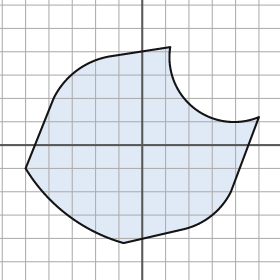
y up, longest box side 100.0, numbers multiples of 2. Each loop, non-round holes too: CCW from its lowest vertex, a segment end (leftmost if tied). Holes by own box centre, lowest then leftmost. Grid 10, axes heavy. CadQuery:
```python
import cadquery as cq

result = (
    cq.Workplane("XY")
    .moveTo(-8.0, -42.0)
    .lineTo(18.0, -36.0)
    .threePointArc((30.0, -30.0), (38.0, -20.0))
    .lineTo(50.0, 12.0)
    .threePointArc((22.0, 16.0), (12.0, 42.0))
    .lineTo(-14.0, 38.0)
    .threePointArc((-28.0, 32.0), (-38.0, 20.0))
    .lineTo(-50.0, -10.0)
    .threePointArc((-32.0, -30.0), (-8.0, -42.0))
    .close()
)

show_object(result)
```